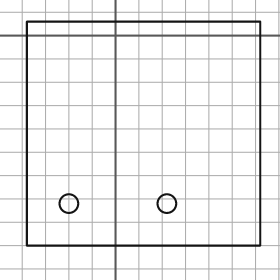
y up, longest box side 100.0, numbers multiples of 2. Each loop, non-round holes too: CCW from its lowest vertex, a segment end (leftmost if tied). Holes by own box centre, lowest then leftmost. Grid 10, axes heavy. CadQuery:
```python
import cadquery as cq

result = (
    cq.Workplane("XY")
    .moveTo(-38.0, -90.0)
    .lineTo(62.0, -90.0)
    .lineTo(62.0, 6.0)
    .lineTo(-38.0, 6.0)
    .close()
    .moveTo(-20.0, -72.0)
    .circle(4.0)
    .moveTo(22.0, -72.0)
    .circle(4.0)
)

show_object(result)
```